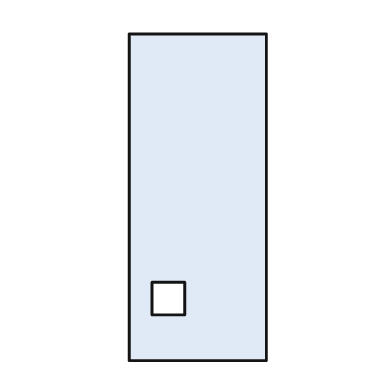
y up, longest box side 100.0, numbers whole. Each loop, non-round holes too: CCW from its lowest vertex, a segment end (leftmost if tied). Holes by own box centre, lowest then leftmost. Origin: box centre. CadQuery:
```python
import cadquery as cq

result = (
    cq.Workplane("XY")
    .moveTo(-21.0, -50.0)
    .lineTo(21.0, -50.0)
    .lineTo(21.0, 50.0)
    .lineTo(-21.0, 50.0)
    .close()
    .moveTo(-14.0, -36.0)
    .lineTo(-4.0, -36.0)
    .lineTo(-4.0, -26.0)
    .lineTo(-14.0, -26.0)
    .close()
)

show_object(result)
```